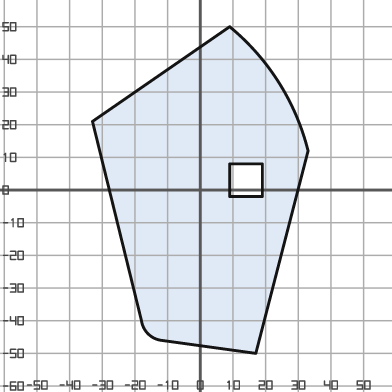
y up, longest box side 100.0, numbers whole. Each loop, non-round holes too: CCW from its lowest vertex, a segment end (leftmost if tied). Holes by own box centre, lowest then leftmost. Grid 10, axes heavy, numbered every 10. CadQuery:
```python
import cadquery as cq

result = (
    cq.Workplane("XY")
    .moveTo(17.0, -50.0)
    .lineTo(33.0, 12.0)
    .threePointArc((24.0, 33.0), (9.0, 50.0))
    .lineTo(-33.0, 21.0)
    .lineTo(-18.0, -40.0)
    .threePointArc((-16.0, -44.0), (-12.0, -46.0))
    .close()
    .moveTo(9.0, -2.0)
    .lineTo(19.0, -2.0)
    .lineTo(19.0, 8.0)
    .lineTo(9.0, 8.0)
    .close()
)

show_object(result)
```